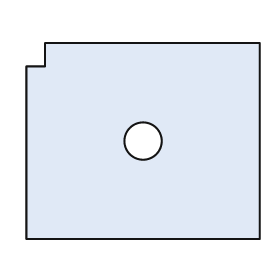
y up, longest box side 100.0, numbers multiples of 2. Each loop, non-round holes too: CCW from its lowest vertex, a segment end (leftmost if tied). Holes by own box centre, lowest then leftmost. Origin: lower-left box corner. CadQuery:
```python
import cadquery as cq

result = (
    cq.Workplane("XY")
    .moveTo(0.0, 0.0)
    .lineTo(100.0, 0.0)
    .lineTo(100.0, 84.0)
    .lineTo(8.0, 84.0)
    .lineTo(8.0, 74.0)
    .lineTo(0.0, 74.0)
    .close()
    .moveTo(50.0, 42.0)
    .circle(8.0)
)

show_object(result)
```